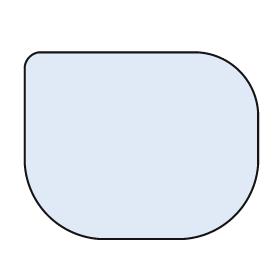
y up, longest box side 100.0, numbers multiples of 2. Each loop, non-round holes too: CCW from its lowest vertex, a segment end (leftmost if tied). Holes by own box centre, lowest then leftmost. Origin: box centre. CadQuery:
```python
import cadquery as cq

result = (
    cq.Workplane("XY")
    .moveTo(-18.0, -40.0)
    .lineTo(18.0, -40.0)
    .threePointArc((40.0, -30.0), (50.0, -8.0))
    .lineTo(50.0, 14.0)
    .threePointArc((42.0, 32.0), (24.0, 40.0))
    .lineTo(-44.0, 40.0)
    .threePointArc((-48.0, 38.0), (-50.0, 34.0))
    .lineTo(-50.0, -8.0)
    .threePointArc((-40.0, -30.0), (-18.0, -40.0))
    .close()
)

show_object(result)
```